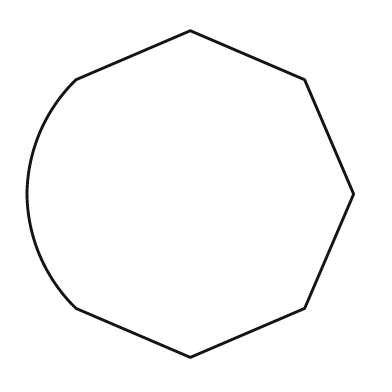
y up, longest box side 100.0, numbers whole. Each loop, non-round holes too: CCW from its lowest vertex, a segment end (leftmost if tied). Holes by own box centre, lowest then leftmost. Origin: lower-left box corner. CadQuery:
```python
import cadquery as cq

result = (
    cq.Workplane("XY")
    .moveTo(50.0, 0.0)
    .lineTo(85.0, 15.0)
    .lineTo(100.0, 50.0)
    .lineTo(85.0, 85.0)
    .lineTo(50.0, 100.0)
    .lineTo(15.0, 85.0)
    .threePointArc((4.0, 69.0), (0.0, 50.0))
    .threePointArc((4.0, 31.0), (15.0, 15.0))
    .close()
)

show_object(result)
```